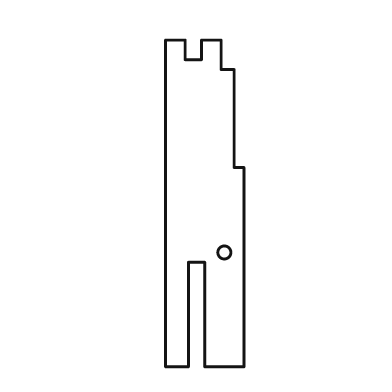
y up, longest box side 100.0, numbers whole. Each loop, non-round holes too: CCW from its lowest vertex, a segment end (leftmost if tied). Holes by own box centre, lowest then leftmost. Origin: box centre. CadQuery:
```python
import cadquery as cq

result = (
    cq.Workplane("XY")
    .moveTo(-12.0, -50.0)
    .lineTo(-5.0, -50.0)
    .lineTo(-5.0, -18.0)
    .lineTo(0.0, -18.0)
    .lineTo(0.0, -50.0)
    .lineTo(12.0, -50.0)
    .lineTo(12.0, 11.0)
    .lineTo(9.0, 11.0)
    .lineTo(9.0, 41.0)
    .lineTo(5.0, 41.0)
    .lineTo(5.0, 50.0)
    .lineTo(-1.0, 50.0)
    .lineTo(-1.0, 44.0)
    .lineTo(-6.0, 44.0)
    .lineTo(-6.0, 50.0)
    .lineTo(-12.0, 50.0)
    .close()
    .moveTo(6.0, -15.0)
    .circle(2.0)
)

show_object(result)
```